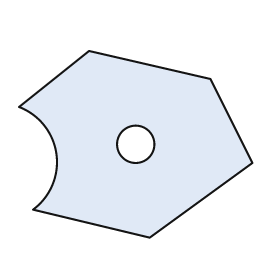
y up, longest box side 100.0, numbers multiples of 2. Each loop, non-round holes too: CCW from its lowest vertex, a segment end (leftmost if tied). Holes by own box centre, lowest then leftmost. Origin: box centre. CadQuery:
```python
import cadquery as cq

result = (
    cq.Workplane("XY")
    .moveTo(6.0, -40.0)
    .lineTo(50.0, -8.0)
    .lineTo(32.0, 28.0)
    .lineTo(-20.0, 40.0)
    .lineTo(-50.0, 16.0)
    .threePointArc((-34.0, -4.0), (-44.0, -28.0))
    .close()
    .moveTo(0.0, 0.0)
    .circle(8.0)
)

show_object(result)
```